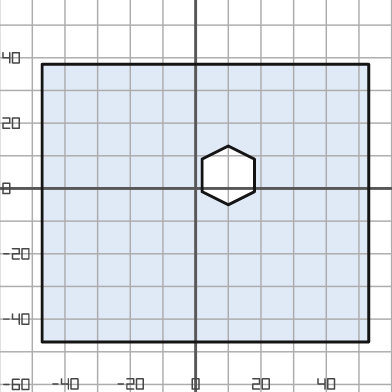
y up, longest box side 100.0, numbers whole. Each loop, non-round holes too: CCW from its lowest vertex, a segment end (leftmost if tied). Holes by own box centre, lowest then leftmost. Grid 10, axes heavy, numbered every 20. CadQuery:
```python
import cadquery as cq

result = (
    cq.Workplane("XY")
    .moveTo(-47.0, -47.0)
    .lineTo(53.0, -47.0)
    .lineTo(53.0, 38.0)
    .lineTo(-47.0, 38.0)
    .close()
    .moveTo(10.0, -5.0)
    .lineTo(18.0, -1.0)
    .lineTo(18.0, 9.0)
    .lineTo(10.0, 13.0)
    .lineTo(2.0, 9.0)
    .lineTo(2.0, -1.0)
    .close()
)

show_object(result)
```